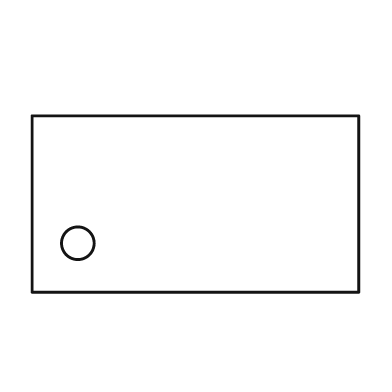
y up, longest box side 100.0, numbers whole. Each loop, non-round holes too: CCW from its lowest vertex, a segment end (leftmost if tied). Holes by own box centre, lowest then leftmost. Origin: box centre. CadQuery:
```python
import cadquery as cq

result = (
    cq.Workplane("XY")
    .moveTo(-50.0, -27.0)
    .lineTo(50.0, -27.0)
    .lineTo(50.0, 27.0)
    .lineTo(-50.0, 27.0)
    .close()
    .moveTo(-36.0, -12.0)
    .circle(5.0)
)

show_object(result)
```